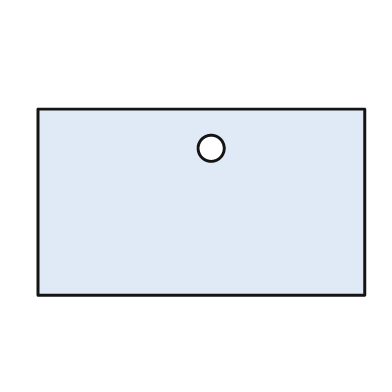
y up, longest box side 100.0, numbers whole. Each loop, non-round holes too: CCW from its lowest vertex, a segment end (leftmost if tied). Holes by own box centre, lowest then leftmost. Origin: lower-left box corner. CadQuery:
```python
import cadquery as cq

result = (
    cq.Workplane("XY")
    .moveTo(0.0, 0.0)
    .lineTo(100.0, 0.0)
    .lineTo(100.0, 57.0)
    .lineTo(0.0, 57.0)
    .close()
    .moveTo(53.0, 45.0)
    .circle(4.0)
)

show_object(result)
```